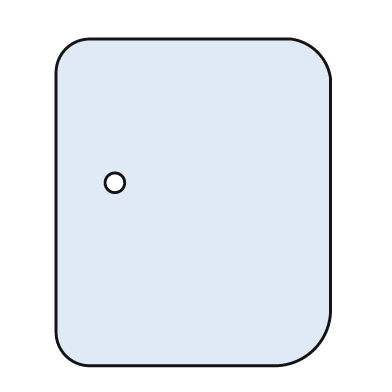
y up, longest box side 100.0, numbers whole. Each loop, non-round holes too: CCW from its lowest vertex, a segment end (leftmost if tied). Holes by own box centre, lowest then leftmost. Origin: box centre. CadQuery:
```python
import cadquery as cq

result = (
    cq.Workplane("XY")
    .moveTo(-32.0, -50.0)
    .lineTo(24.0, -50.0)
    .threePointArc((37.0, -45.0), (42.0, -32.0))
    .lineTo(42.0, 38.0)
    .threePointArc((38.0, 46.0), (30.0, 50.0))
    .lineTo(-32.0, 50.0)
    .threePointArc((-39.0, 47.0), (-42.0, 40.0))
    .lineTo(-42.0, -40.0)
    .threePointArc((-39.0, -47.0), (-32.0, -50.0))
    .close()
    .moveTo(-24.0, 6.0)
    .circle(3.0)
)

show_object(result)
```